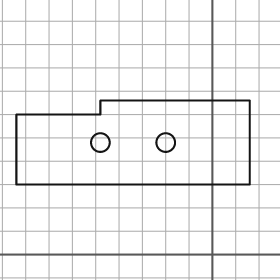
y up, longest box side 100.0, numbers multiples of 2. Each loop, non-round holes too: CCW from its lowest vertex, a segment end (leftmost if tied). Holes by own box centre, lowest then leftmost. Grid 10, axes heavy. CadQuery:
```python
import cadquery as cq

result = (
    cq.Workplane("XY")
    .moveTo(-84.0, 30.0)
    .lineTo(16.0, 30.0)
    .lineTo(16.0, 66.0)
    .lineTo(-48.0, 66.0)
    .lineTo(-48.0, 60.0)
    .lineTo(-84.0, 60.0)
    .close()
    .moveTo(-48.0, 48.0)
    .circle(4.0)
    .moveTo(-20.0, 48.0)
    .circle(4.0)
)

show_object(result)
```